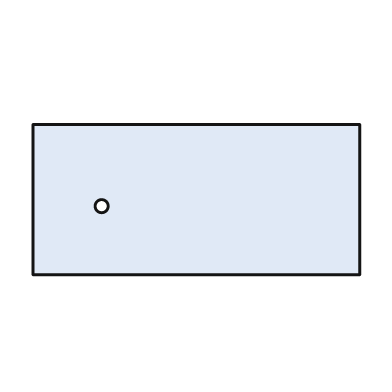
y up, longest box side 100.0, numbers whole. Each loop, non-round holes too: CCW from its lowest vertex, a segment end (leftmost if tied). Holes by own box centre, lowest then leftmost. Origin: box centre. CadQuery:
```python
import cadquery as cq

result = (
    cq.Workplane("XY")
    .moveTo(-50.0, -23.0)
    .lineTo(50.0, -23.0)
    .lineTo(50.0, 23.0)
    .lineTo(-50.0, 23.0)
    .close()
    .moveTo(-29.0, -2.0)
    .circle(2.0)
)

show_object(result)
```